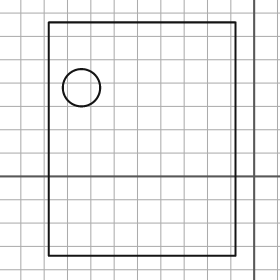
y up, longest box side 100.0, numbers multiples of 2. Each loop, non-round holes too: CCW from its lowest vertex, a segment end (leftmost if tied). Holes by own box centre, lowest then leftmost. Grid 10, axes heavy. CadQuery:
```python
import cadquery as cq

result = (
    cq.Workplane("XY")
    .moveTo(-88.0, -34.0)
    .lineTo(-8.0, -34.0)
    .lineTo(-8.0, 66.0)
    .lineTo(-88.0, 66.0)
    .close()
    .moveTo(-74.0, 38.0)
    .circle(8.0)
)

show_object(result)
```